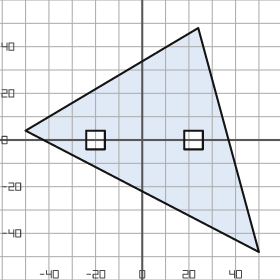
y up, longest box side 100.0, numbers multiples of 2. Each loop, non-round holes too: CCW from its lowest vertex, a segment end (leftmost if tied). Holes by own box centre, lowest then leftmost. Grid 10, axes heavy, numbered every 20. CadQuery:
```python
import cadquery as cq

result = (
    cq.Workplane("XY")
    .moveTo(50.0, -48.0)
    .lineTo(24.0, 48.0)
    .lineTo(-50.0, 4.0)
    .close()
    .moveTo(-24.0, -4.0)
    .lineTo(-16.0, -4.0)
    .lineTo(-16.0, 4.0)
    .lineTo(-24.0, 4.0)
    .close()
    .moveTo(18.0, -4.0)
    .lineTo(26.0, -4.0)
    .lineTo(26.0, 4.0)
    .lineTo(18.0, 4.0)
    .close()
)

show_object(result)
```